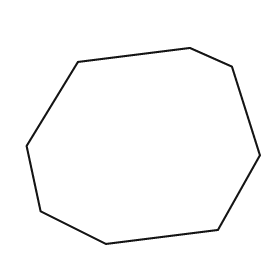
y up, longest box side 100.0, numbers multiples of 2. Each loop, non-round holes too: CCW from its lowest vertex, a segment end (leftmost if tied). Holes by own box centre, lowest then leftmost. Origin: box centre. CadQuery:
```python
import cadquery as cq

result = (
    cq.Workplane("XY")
    .moveTo(-16.0, -42.0)
    .lineTo(32.0, -36.0)
    .lineTo(50.0, -4.0)
    .lineTo(38.0, 34.0)
    .lineTo(20.0, 42.0)
    .lineTo(-28.0, 36.0)
    .lineTo(-50.0, 0.0)
    .lineTo(-44.0, -28.0)
    .close()
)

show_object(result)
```